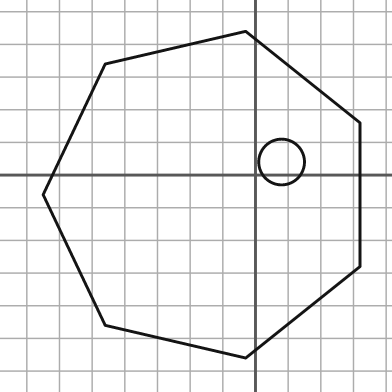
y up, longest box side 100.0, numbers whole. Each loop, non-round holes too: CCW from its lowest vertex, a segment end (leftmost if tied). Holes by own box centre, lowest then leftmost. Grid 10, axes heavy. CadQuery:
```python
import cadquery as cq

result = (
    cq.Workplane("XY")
    .moveTo(-3.0, -56.0)
    .lineTo(32.0, -28.0)
    .lineTo(32.0, 16.0)
    .lineTo(-3.0, 44.0)
    .lineTo(-46.0, 34.0)
    .lineTo(-65.0, -6.0)
    .lineTo(-46.0, -46.0)
    .close()
    .moveTo(8.0, 4.0)
    .circle(7.0)
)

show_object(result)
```